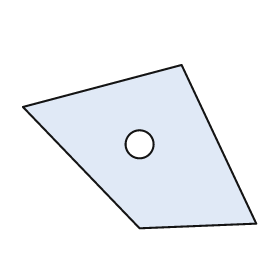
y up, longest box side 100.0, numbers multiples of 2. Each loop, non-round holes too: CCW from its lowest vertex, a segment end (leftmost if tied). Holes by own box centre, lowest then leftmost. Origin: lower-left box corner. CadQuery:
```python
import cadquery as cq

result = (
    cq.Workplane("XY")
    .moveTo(50.0, 0.0)
    .lineTo(100.0, 2.0)
    .lineTo(68.0, 70.0)
    .lineTo(0.0, 52.0)
    .close()
    .moveTo(50.0, 36.0)
    .circle(6.0)
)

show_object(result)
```